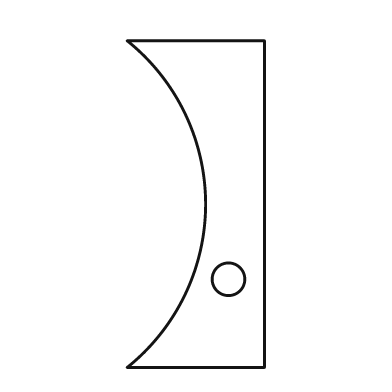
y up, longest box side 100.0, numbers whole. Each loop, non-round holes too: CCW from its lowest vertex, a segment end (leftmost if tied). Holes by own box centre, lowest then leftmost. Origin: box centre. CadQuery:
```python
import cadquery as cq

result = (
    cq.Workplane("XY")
    .moveTo(-21.0, -50.0)
    .lineTo(21.0, -50.0)
    .lineTo(21.0, 50.0)
    .lineTo(-21.0, 50.0)
    .threePointArc((3.0, 0.0), (-21.0, -50.0))
    .close()
    .moveTo(10.0, -23.0)
    .circle(5.0)
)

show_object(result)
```